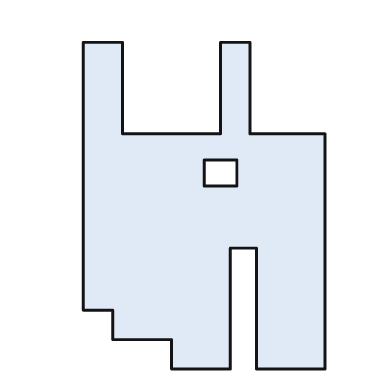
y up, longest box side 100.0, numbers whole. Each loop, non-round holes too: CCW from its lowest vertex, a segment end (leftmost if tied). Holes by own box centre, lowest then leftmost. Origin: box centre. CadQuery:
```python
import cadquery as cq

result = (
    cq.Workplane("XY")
    .moveTo(-10.0, -50.0)
    .lineTo(8.0, -50.0)
    .lineTo(8.0, -13.0)
    .lineTo(16.0, -13.0)
    .lineTo(16.0, -50.0)
    .lineTo(37.0, -50.0)
    .lineTo(37.0, 22.0)
    .lineTo(14.0, 22.0)
    .lineTo(14.0, 50.0)
    .lineTo(5.0, 50.0)
    .lineTo(5.0, 22.0)
    .lineTo(-25.0, 22.0)
    .lineTo(-25.0, 50.0)
    .lineTo(-37.0, 50.0)
    .lineTo(-37.0, -32.0)
    .lineTo(-28.0, -32.0)
    .lineTo(-28.0, -41.0)
    .lineTo(-10.0, -41.0)
    .close()
    .moveTo(0.0, 6.0)
    .lineTo(10.0, 6.0)
    .lineTo(10.0, 14.0)
    .lineTo(0.0, 14.0)
    .close()
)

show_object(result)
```